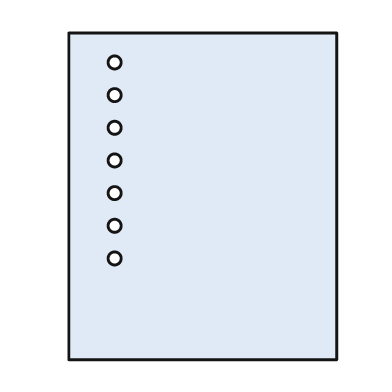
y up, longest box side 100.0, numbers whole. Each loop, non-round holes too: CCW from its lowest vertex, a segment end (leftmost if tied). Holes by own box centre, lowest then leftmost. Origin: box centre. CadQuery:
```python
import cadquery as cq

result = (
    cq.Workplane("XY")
    .moveTo(-41.0, -50.0)
    .lineTo(41.0, -50.0)
    .lineTo(41.0, 50.0)
    .lineTo(-41.0, 50.0)
    .close()
    .moveTo(-27.0, -19.0)
    .circle(2.0)
    .moveTo(-27.0, -9.0)
    .circle(2.0)
    .moveTo(-27.0, 1.0)
    .circle(2.0)
    .moveTo(-27.0, 11.0)
    .circle(2.0)
    .moveTo(-27.0, 21.0)
    .circle(2.0)
    .moveTo(-27.0, 31.0)
    .circle(2.0)
    .moveTo(-27.0, 41.0)
    .circle(2.0)
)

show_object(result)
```